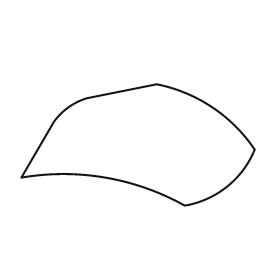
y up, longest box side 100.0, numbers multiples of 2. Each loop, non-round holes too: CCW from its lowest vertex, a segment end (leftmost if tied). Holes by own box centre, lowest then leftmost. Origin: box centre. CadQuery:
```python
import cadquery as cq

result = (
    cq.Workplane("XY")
    .moveTo(20.0, -26.0)
    .threePointArc((38.0, -18.0), (50.0, -2.0))
    .threePointArc((32.0, 16.0), (8.0, 26.0))
    .lineTo(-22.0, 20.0)
    .threePointArc((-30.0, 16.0), (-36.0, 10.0))
    .lineTo(-50.0, -14.0)
    .threePointArc((-14.0, -14.0), (20.0, -26.0))
    .close()
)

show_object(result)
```